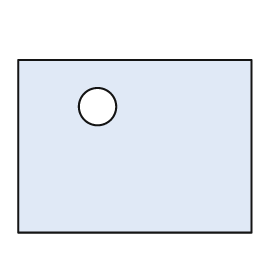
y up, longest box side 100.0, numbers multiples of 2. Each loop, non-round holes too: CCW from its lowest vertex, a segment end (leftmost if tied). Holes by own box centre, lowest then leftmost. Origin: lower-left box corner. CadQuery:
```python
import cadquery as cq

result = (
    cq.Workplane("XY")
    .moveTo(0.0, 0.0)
    .lineTo(100.0, 0.0)
    .lineTo(100.0, 74.0)
    .lineTo(0.0, 74.0)
    .close()
    .moveTo(34.0, 54.0)
    .circle(8.0)
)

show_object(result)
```